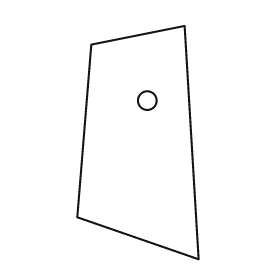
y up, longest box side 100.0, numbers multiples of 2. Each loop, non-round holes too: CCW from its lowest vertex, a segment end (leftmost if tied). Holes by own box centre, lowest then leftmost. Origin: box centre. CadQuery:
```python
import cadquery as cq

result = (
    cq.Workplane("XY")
    .moveTo(26.0, -50.0)
    .lineTo(20.0, 50.0)
    .lineTo(-20.0, 42.0)
    .lineTo(-26.0, -32.0)
    .close()
    .moveTo(4.0, 18.0)
    .circle(4.0)
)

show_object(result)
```